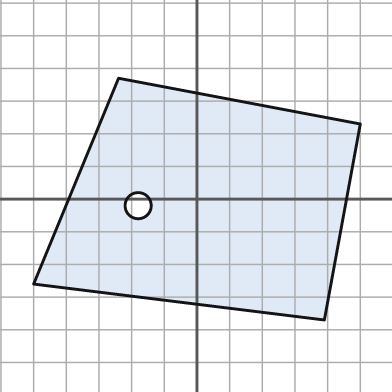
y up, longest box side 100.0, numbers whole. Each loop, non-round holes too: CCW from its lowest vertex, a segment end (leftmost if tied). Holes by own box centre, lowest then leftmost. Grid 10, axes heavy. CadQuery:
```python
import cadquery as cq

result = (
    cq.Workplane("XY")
    .moveTo(39.0, -37.0)
    .lineTo(50.0, 23.0)
    .lineTo(-24.0, 37.0)
    .lineTo(-50.0, -26.0)
    .close()
    .moveTo(-18.0, -2.0)
    .circle(4.0)
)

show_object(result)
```